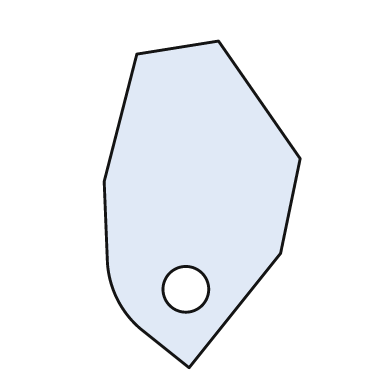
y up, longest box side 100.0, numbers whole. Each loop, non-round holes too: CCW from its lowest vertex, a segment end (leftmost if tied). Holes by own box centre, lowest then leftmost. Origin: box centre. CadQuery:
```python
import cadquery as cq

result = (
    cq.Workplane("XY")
    .moveTo(-4.0, -50.0)
    .lineTo(24.0, -15.0)
    .lineTo(30.0, 14.0)
    .lineTo(5.0, 50.0)
    .lineTo(-20.0, 46.0)
    .lineTo(-30.0, 7.0)
    .lineTo(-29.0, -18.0)
    .threePointArc((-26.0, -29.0), (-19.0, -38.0))
    .close()
    .moveTo(-5.0, -26.0)
    .circle(7.0)
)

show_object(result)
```